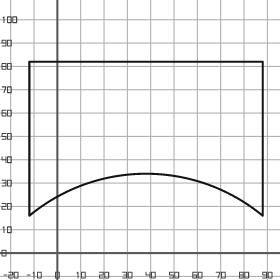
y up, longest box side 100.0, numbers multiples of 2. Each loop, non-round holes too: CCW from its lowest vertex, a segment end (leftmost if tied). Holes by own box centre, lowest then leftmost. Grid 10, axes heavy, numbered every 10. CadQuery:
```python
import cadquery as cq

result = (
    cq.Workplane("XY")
    .moveTo(-12.0, 16.0)
    .threePointArc((38.0, 34.0), (88.0, 16.0))
    .lineTo(88.0, 82.0)
    .lineTo(-12.0, 82.0)
    .close()
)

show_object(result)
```